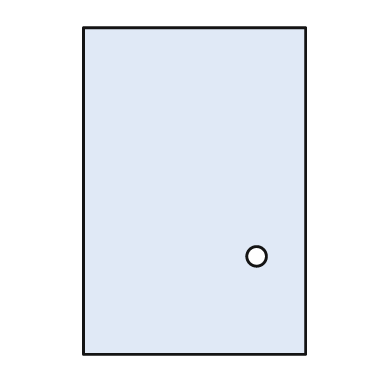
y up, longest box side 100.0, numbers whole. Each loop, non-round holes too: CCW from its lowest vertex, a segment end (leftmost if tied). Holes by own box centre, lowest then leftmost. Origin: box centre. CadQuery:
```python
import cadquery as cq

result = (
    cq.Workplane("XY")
    .moveTo(-34.0, -50.0)
    .lineTo(34.0, -50.0)
    .lineTo(34.0, 50.0)
    .lineTo(-34.0, 50.0)
    .close()
    .moveTo(19.0, -20.0)
    .circle(3.0)
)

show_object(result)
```